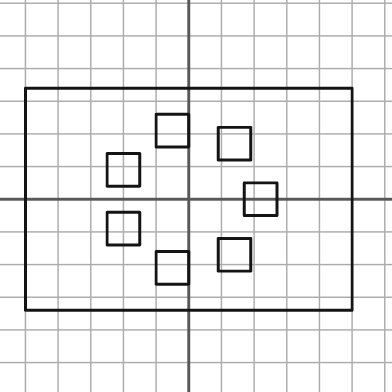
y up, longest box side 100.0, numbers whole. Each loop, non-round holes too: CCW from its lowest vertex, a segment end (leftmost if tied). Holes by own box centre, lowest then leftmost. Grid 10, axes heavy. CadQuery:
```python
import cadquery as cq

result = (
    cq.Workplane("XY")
    .moveTo(-50.0, -34.0)
    .lineTo(50.0, -34.0)
    .lineTo(50.0, 34.0)
    .lineTo(-50.0, 34.0)
    .close()
    .moveTo(-10.0, -26.0)
    .lineTo(0.0, -26.0)
    .lineTo(0.0, -16.0)
    .lineTo(-10.0, -16.0)
    .close()
    .moveTo(9.0, -22.0)
    .lineTo(19.0, -22.0)
    .lineTo(19.0, -12.0)
    .lineTo(9.0, -12.0)
    .close()
    .moveTo(-25.0, -14.0)
    .lineTo(-15.0, -14.0)
    .lineTo(-15.0, -4.0)
    .lineTo(-25.0, -4.0)
    .close()
    .moveTo(17.0, -5.0)
    .lineTo(27.0, -5.0)
    .lineTo(27.0, 5.0)
    .lineTo(17.0, 5.0)
    .close()
    .moveTo(-25.0, 4.0)
    .lineTo(-15.0, 4.0)
    .lineTo(-15.0, 14.0)
    .lineTo(-25.0, 14.0)
    .close()
    .moveTo(9.0, 12.0)
    .lineTo(19.0, 12.0)
    .lineTo(19.0, 22.0)
    .lineTo(9.0, 22.0)
    .close()
    .moveTo(-10.0, 16.0)
    .lineTo(0.0, 16.0)
    .lineTo(0.0, 26.0)
    .lineTo(-10.0, 26.0)
    .close()
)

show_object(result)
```